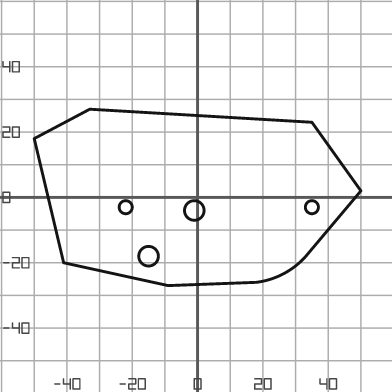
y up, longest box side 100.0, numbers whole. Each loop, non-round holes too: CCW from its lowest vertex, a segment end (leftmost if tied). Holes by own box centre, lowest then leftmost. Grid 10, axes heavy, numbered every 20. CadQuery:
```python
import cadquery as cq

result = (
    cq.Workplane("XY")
    .moveTo(-9.0, -27.0)
    .lineTo(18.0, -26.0)
    .threePointArc((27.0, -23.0), (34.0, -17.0))
    .lineTo(50.0, 2.0)
    .lineTo(35.0, 23.0)
    .lineTo(-33.0, 27.0)
    .lineTo(-50.0, 18.0)
    .lineTo(-41.0, -20.0)
    .close()
    .moveTo(-15.0, -18.0)
    .circle(3.0)
    .moveTo(-1.0, -4.0)
    .circle(3.0)
    .moveTo(-22.0, -3.0)
    .circle(2.0)
    .moveTo(35.0, -3.0)
    .circle(2.0)
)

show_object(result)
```